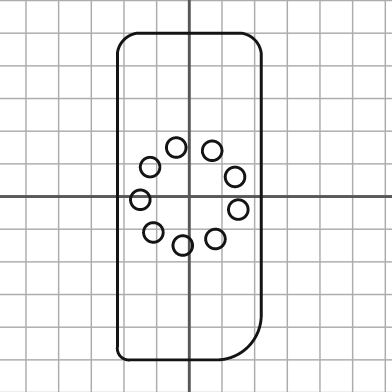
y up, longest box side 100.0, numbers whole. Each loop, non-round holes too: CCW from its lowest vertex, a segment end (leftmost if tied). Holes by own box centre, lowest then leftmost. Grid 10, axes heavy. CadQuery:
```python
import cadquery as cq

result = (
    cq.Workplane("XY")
    .moveTo(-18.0, -50.0)
    .lineTo(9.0, -50.0)
    .threePointArc((18.0, -46.0), (22.0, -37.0))
    .lineTo(22.0, 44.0)
    .threePointArc((20.0, 48.0), (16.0, 50.0))
    .lineTo(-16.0, 50.0)
    .threePointArc((-20.0, 48.0), (-22.0, 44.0))
    .lineTo(-22.0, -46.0)
    .threePointArc((-21.0, -49.0), (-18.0, -50.0))
    .close()
    .moveTo(-2.0, -15.0)
    .circle(3.0)
    .moveTo(8.0, -13.0)
    .circle(3.0)
    .moveTo(-11.0, -11.0)
    .circle(3.0)
    .moveTo(15.0, -4.0)
    .circle(3.0)
    .moveTo(-15.0, -1.0)
    .circle(3.0)
    .moveTo(14.0, 6.0)
    .circle(3.0)
    .moveTo(-12.0, 9.0)
    .circle(3.0)
    .moveTo(7.0, 14.0)
    .circle(3.0)
    .moveTo(-4.0, 15.0)
    .circle(3.0)
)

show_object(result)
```